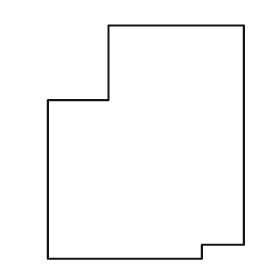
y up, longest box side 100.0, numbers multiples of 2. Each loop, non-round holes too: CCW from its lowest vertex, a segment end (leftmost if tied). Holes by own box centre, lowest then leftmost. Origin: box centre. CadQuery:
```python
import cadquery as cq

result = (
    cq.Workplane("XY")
    .moveTo(-42.0, -50.0)
    .lineTo(24.0, -50.0)
    .lineTo(24.0, -44.0)
    .lineTo(42.0, -44.0)
    .lineTo(42.0, 50.0)
    .lineTo(-16.0, 50.0)
    .lineTo(-16.0, 18.0)
    .lineTo(-42.0, 18.0)
    .close()
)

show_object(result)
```